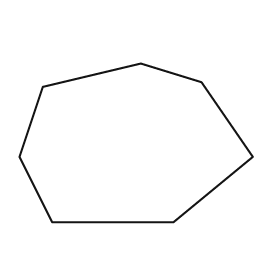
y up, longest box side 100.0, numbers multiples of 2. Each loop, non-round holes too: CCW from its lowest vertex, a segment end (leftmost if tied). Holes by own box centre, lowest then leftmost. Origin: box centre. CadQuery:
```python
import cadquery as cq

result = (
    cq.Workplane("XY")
    .moveTo(-36.0, -34.0)
    .lineTo(16.0, -34.0)
    .lineTo(50.0, -6.0)
    .lineTo(28.0, 26.0)
    .lineTo(2.0, 34.0)
    .lineTo(-40.0, 24.0)
    .lineTo(-50.0, -6.0)
    .close()
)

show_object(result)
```